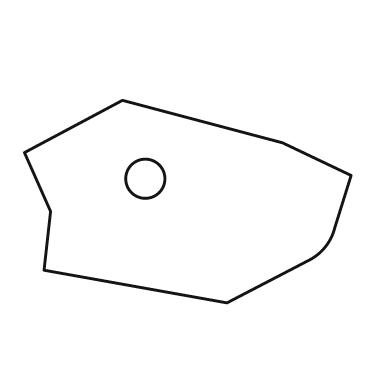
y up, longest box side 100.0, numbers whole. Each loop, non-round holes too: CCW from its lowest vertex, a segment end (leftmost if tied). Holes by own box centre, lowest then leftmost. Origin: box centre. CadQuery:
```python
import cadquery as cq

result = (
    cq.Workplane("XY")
    .moveTo(12.0, -31.0)
    .lineTo(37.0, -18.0)
    .threePointArc((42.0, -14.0), (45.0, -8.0))
    .lineTo(50.0, 8.0)
    .lineTo(29.0, 18.0)
    .lineTo(-20.0, 31.0)
    .lineTo(-50.0, 15.0)
    .lineTo(-42.0, -3.0)
    .lineTo(-44.0, -21.0)
    .close()
    .moveTo(-13.0, 7.0)
    .circle(6.0)
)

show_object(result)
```